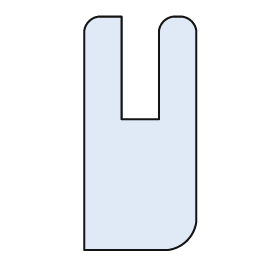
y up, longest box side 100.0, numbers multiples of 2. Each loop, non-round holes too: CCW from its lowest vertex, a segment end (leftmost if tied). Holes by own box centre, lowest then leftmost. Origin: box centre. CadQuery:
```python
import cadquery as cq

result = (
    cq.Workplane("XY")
    .moveTo(-24.0, -50.0)
    .lineTo(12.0, -50.0)
    .threePointArc((20.0, -46.0), (24.0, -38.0))
    .lineTo(24.0, 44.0)
    .threePointArc((22.0, 48.0), (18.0, 50.0))
    .lineTo(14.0, 50.0)
    .threePointArc((10.0, 48.0), (8.0, 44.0))
    .lineTo(8.0, 6.0)
    .lineTo(-8.0, 6.0)
    .lineTo(-8.0, 50.0)
    .lineTo(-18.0, 50.0)
    .threePointArc((-22.0, 48.0), (-24.0, 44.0))
    .close()
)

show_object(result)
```